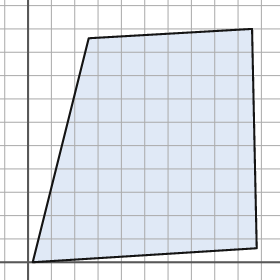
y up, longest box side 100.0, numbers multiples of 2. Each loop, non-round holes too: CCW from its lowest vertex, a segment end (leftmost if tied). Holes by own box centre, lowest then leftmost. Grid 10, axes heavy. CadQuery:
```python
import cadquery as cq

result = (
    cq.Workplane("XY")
    .moveTo(2.0, 0.0)
    .lineTo(98.0, 6.0)
    .lineTo(96.0, 100.0)
    .lineTo(26.0, 96.0)
    .close()
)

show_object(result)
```